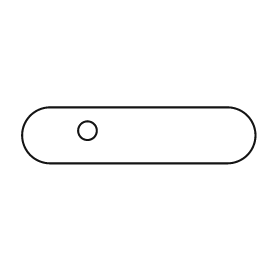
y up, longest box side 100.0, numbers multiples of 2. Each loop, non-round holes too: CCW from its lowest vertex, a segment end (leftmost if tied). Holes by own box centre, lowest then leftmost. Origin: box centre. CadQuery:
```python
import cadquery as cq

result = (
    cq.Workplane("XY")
    .moveTo(-38.0, -12.0)
    .lineTo(38.0, -12.0)
    .threePointArc((50.0, 0.0), (38.0, 12.0))
    .lineTo(-38.0, 12.0)
    .threePointArc((-50.0, 0.0), (-38.0, -12.0))
    .close()
    .moveTo(-22.0, 2.0)
    .circle(4.0)
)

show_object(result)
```